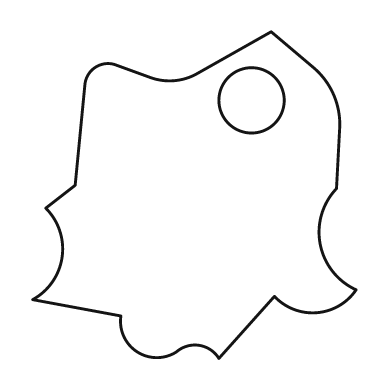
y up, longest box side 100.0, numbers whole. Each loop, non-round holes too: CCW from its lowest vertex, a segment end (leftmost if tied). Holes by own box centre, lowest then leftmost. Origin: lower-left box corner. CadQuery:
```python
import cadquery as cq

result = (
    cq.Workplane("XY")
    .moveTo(57.0, 0.0)
    .lineTo(74.0, 19.0)
    .threePointArc((87.0, 14.0), (99.0, 21.0))
    .threePointArc((88.0, 35.0), (93.0, 52.0))
    .lineTo(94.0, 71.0)
    .threePointArc((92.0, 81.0), (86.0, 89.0))
    .lineTo(73.0, 100.0)
    .lineTo(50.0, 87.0)
    .threePointArc((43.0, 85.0), (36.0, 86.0))
    .lineTo(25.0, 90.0)
    .threePointArc((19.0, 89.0), (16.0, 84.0))
    .lineTo(13.0, 53.0)
    .lineTo(4.0, 46.0)
    .threePointArc((9.0, 31.0), (0.0, 18.0))
    .lineTo(27.0, 13.0)
    .threePointArc((32.0, 2.0), (44.0, 2.0))
    .threePointArc((51.0, 4.0), (57.0, 0.0))
    .close()
    .moveTo(67.0, 79.0)
    .circle(10.0)
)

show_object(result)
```